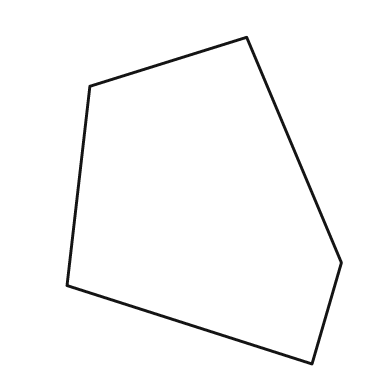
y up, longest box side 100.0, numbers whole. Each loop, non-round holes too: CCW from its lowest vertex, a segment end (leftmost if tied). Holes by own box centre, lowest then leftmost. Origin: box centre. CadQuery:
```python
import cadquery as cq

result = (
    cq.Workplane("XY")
    .moveTo(33.0, -50.0)
    .lineTo(42.0, -19.0)
    .lineTo(13.0, 50.0)
    .lineTo(-35.0, 35.0)
    .lineTo(-42.0, -26.0)
    .close()
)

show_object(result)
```